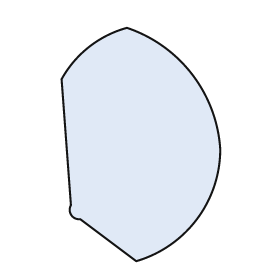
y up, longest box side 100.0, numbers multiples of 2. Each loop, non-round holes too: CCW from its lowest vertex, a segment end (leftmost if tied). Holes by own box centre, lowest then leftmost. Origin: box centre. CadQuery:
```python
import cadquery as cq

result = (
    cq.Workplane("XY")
    .moveTo(-2.0, -50.0)
    .threePointArc((24.0, -32.0), (34.0, -2.0))
    .threePointArc((22.0, 30.0), (-6.0, 50.0))
    .threePointArc((-22.0, 42.0), (-34.0, 28.0))
    .lineTo(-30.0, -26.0)
    .threePointArc((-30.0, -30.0), (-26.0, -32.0))
    .close()
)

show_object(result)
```